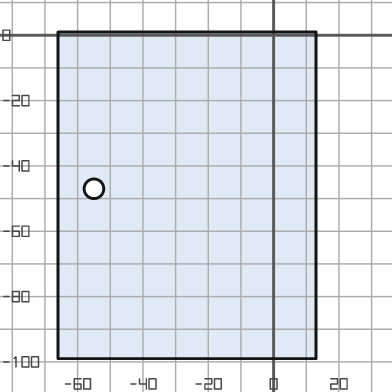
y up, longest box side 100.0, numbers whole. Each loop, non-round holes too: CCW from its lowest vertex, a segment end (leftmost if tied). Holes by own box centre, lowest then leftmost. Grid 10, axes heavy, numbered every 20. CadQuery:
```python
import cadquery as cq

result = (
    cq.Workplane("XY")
    .moveTo(-66.0, -99.0)
    .lineTo(13.0, -99.0)
    .lineTo(13.0, 1.0)
    .lineTo(-66.0, 1.0)
    .close()
    .moveTo(-55.0, -47.0)
    .circle(3.0)
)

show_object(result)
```